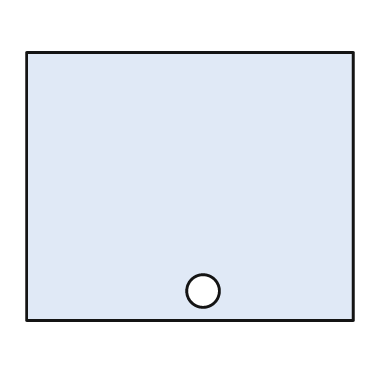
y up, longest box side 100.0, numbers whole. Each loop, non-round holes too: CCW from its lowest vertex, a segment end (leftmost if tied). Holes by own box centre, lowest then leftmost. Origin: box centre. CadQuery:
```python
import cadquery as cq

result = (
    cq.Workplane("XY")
    .moveTo(-50.0, -41.0)
    .lineTo(50.0, -41.0)
    .lineTo(50.0, 41.0)
    .lineTo(-50.0, 41.0)
    .close()
    .moveTo(4.0, -32.0)
    .circle(5.0)
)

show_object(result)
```